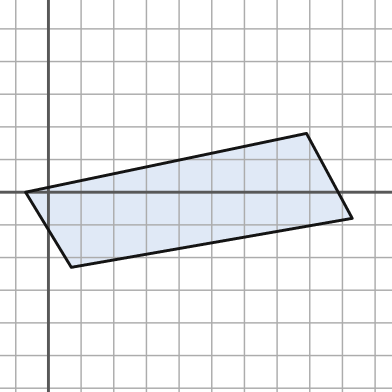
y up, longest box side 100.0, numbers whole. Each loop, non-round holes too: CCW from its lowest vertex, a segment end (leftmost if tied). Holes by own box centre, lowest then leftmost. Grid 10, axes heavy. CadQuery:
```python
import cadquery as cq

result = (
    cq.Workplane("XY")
    .moveTo(7.0, -23.0)
    .lineTo(93.0, -8.0)
    .lineTo(79.0, 18.0)
    .lineTo(-7.0, 0.0)
    .close()
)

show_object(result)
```